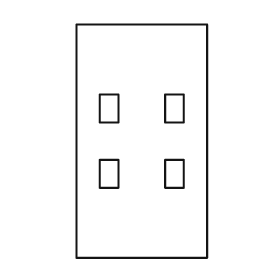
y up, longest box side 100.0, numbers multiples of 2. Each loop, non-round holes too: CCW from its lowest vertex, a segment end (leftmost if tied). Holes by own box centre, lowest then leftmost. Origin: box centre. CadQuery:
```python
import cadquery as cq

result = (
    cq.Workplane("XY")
    .moveTo(-28.0, -50.0)
    .lineTo(28.0, -50.0)
    .lineTo(28.0, 50.0)
    .lineTo(-28.0, 50.0)
    .close()
    .moveTo(-18.0, -20.0)
    .lineTo(-10.0, -20.0)
    .lineTo(-10.0, -8.0)
    .lineTo(-18.0, -8.0)
    .close()
    .moveTo(10.0, -20.0)
    .lineTo(18.0, -20.0)
    .lineTo(18.0, -8.0)
    .lineTo(10.0, -8.0)
    .close()
    .moveTo(-18.0, 8.0)
    .lineTo(-10.0, 8.0)
    .lineTo(-10.0, 20.0)
    .lineTo(-18.0, 20.0)
    .close()
    .moveTo(10.0, 8.0)
    .lineTo(18.0, 8.0)
    .lineTo(18.0, 20.0)
    .lineTo(10.0, 20.0)
    .close()
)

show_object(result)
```